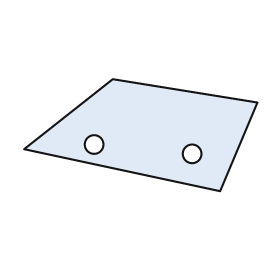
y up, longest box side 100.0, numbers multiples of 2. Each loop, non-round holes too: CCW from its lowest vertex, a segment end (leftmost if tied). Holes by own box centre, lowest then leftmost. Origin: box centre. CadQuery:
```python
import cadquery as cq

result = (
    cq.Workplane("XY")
    .moveTo(34.0, -24.0)
    .lineTo(50.0, 14.0)
    .lineTo(-12.0, 24.0)
    .lineTo(-50.0, -6.0)
    .close()
    .moveTo(22.0, -8.0)
    .circle(4.0)
    .moveTo(-20.0, -4.0)
    .circle(4.0)
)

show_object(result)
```